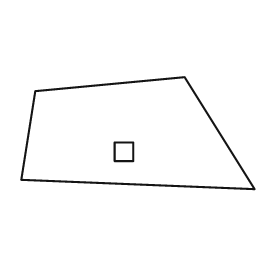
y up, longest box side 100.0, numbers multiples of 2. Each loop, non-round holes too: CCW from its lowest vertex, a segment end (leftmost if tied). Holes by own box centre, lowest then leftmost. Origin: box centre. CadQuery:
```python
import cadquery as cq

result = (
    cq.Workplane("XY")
    .moveTo(50.0, -24.0)
    .lineTo(20.0, 24.0)
    .lineTo(-44.0, 18.0)
    .lineTo(-50.0, -20.0)
    .close()
    .moveTo(-10.0, -12.0)
    .lineTo(-2.0, -12.0)
    .lineTo(-2.0, -4.0)
    .lineTo(-10.0, -4.0)
    .close()
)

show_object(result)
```